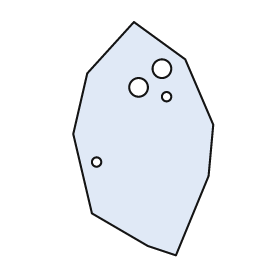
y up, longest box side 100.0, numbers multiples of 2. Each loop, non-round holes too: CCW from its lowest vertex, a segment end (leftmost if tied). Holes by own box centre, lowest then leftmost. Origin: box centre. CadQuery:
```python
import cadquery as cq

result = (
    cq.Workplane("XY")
    .moveTo(14.0, -50.0)
    .lineTo(28.0, -16.0)
    .lineTo(30.0, 6.0)
    .lineTo(18.0, 34.0)
    .lineTo(-4.0, 50.0)
    .lineTo(-24.0, 28.0)
    .lineTo(-30.0, 2.0)
    .lineTo(-22.0, -32.0)
    .lineTo(2.0, -46.0)
    .close()
    .moveTo(-20.0, -10.0)
    .circle(2.0)
    .moveTo(10.0, 18.0)
    .circle(2.0)
    .moveTo(-2.0, 22.0)
    .circle(4.0)
    .moveTo(8.0, 30.0)
    .circle(4.0)
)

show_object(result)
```